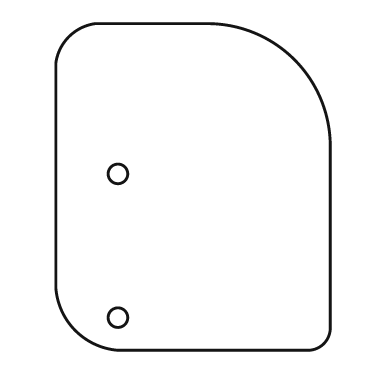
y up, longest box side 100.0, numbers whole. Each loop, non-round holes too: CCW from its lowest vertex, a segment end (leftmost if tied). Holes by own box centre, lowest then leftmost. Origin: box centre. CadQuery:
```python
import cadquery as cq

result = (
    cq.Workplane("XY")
    .moveTo(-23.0, -50.0)
    .lineTo(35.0, -50.0)
    .threePointArc((40.0, -48.0), (42.0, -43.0))
    .lineTo(42.0, 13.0)
    .threePointArc((31.0, 39.0), (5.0, 50.0))
    .lineTo(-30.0, 50.0)
    .threePointArc((-38.0, 46.0), (-42.0, 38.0))
    .lineTo(-42.0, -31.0)
    .threePointArc((-36.0, -44.0), (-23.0, -50.0))
    .close()
    .moveTo(-23.0, -40.0)
    .circle(3.0)
    .moveTo(-23.0, 4.0)
    .circle(3.0)
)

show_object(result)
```